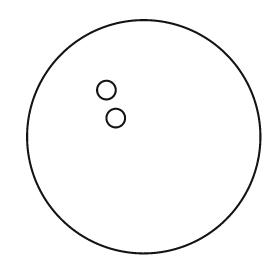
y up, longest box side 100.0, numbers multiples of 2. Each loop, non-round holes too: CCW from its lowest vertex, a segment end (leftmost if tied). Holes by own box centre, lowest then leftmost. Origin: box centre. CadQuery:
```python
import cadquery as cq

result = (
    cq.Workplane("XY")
    .moveTo(0.0, 0.0)
    .circle(50.0)
    .moveTo(-12.0, 8.0)
    .circle(4.0)
    .moveTo(-16.0, 20.0)
    .circle(4.0)
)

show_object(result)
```